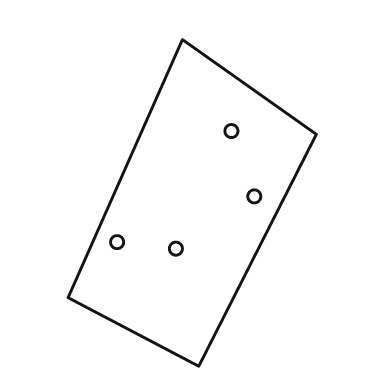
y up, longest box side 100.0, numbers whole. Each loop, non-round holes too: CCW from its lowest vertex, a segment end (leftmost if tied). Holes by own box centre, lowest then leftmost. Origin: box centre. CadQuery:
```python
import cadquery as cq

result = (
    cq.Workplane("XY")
    .moveTo(2.0, -50.0)
    .lineTo(38.0, 21.0)
    .lineTo(-3.0, 50.0)
    .lineTo(-38.0, -29.0)
    .close()
    .moveTo(-5.0, -14.0)
    .circle(2.0)
    .moveTo(-23.0, -12.0)
    .circle(2.0)
    .moveTo(19.0, 2.0)
    .circle(2.0)
    .moveTo(12.0, 22.0)
    .circle(2.0)
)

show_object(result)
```